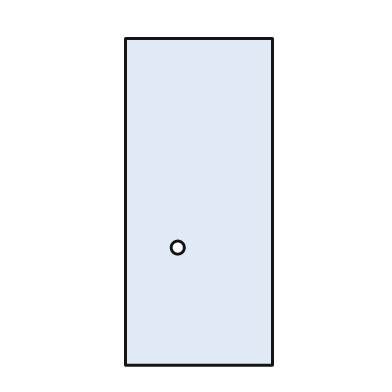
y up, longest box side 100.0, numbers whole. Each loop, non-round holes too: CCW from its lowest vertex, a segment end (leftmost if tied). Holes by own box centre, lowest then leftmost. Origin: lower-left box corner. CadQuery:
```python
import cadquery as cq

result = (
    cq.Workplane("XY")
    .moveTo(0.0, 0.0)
    .lineTo(45.0, 0.0)
    .lineTo(45.0, 100.0)
    .lineTo(0.0, 100.0)
    .close()
    .moveTo(16.0, 36.0)
    .circle(2.0)
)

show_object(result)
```